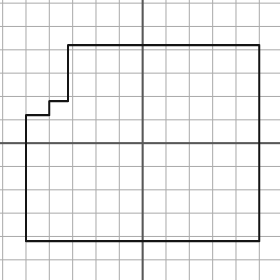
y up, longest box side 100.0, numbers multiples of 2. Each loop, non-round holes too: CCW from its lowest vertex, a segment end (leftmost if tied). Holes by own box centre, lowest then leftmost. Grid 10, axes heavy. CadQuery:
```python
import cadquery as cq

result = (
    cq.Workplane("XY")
    .moveTo(-50.0, -42.0)
    .lineTo(50.0, -42.0)
    .lineTo(50.0, 42.0)
    .lineTo(-32.0, 42.0)
    .lineTo(-32.0, 18.0)
    .lineTo(-40.0, 18.0)
    .lineTo(-40.0, 12.0)
    .lineTo(-50.0, 12.0)
    .close()
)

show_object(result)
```